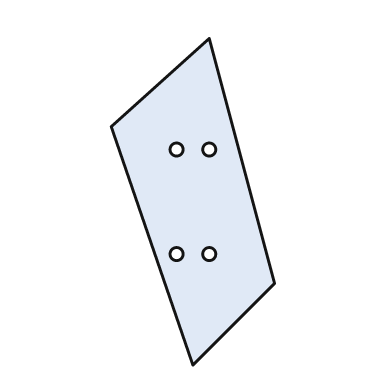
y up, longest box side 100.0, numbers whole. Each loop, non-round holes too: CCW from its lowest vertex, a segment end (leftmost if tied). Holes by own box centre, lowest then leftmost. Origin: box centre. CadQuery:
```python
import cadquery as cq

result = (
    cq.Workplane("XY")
    .moveTo(0.0, -50.0)
    .lineTo(25.0, -25.0)
    .lineTo(5.0, 50.0)
    .lineTo(-25.0, 23.0)
    .close()
    .moveTo(-5.0, -16.0)
    .circle(2.0)
    .moveTo(5.0, -16.0)
    .circle(2.0)
    .moveTo(-5.0, 16.0)
    .circle(2.0)
    .moveTo(5.0, 16.0)
    .circle(2.0)
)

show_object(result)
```